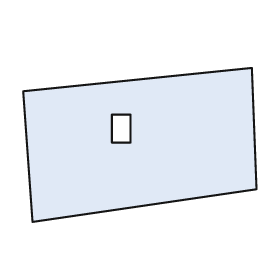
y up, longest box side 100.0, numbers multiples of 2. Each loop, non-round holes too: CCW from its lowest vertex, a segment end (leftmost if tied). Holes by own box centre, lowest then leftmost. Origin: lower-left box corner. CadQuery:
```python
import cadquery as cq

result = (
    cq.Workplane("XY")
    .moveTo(4.0, 0.0)
    .lineTo(100.0, 14.0)
    .lineTo(98.0, 66.0)
    .lineTo(0.0, 56.0)
    .close()
    .moveTo(38.0, 34.0)
    .lineTo(46.0, 34.0)
    .lineTo(46.0, 46.0)
    .lineTo(38.0, 46.0)
    .close()
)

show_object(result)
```